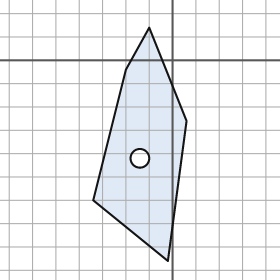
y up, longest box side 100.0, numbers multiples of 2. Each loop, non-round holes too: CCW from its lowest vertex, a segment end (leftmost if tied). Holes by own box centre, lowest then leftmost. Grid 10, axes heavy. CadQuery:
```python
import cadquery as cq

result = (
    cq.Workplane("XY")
    .moveTo(-2.0, -86.0)
    .lineTo(6.0, -26.0)
    .lineTo(-10.0, 14.0)
    .lineTo(-20.0, -4.0)
    .lineTo(-34.0, -60.0)
    .close()
    .moveTo(-14.0, -42.0)
    .circle(4.0)
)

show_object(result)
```